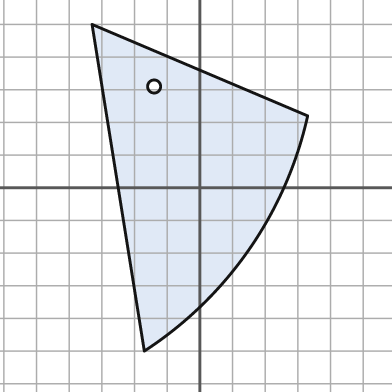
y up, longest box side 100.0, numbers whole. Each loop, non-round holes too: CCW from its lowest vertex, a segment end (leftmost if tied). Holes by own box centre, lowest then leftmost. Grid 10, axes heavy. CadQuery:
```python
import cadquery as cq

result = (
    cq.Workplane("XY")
    .moveTo(-17.0, -50.0)
    .threePointArc((15.0, -19.0), (33.0, 22.0))
    .lineTo(-33.0, 50.0)
    .close()
    .moveTo(-14.0, 31.0)
    .circle(2.0)
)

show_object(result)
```